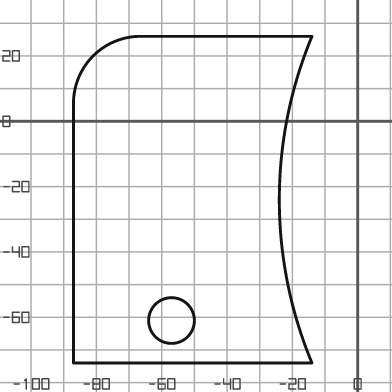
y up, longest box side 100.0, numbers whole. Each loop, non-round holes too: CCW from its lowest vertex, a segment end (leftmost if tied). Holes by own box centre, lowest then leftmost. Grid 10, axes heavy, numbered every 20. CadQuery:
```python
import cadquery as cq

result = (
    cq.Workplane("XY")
    .moveTo(-87.0, -74.0)
    .lineTo(-14.0, -74.0)
    .threePointArc((-24.0, -24.0), (-14.0, 26.0))
    .lineTo(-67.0, 26.0)
    .threePointArc((-81.0, 20.0), (-87.0, 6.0))
    .close()
    .moveTo(-57.0, -61.0)
    .circle(7.0)
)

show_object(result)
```